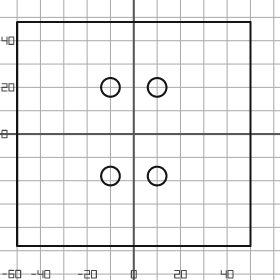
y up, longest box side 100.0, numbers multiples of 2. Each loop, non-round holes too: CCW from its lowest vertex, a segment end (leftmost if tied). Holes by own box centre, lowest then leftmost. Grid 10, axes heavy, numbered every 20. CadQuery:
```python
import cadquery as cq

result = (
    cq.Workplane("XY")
    .moveTo(-50.0, -48.0)
    .lineTo(50.0, -48.0)
    .lineTo(50.0, 48.0)
    .lineTo(-50.0, 48.0)
    .close()
    .moveTo(-10.0, -18.0)
    .circle(4.0)
    .moveTo(10.0, -18.0)
    .circle(4.0)
    .moveTo(-10.0, 20.0)
    .circle(4.0)
    .moveTo(10.0, 20.0)
    .circle(4.0)
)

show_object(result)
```